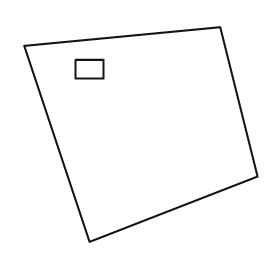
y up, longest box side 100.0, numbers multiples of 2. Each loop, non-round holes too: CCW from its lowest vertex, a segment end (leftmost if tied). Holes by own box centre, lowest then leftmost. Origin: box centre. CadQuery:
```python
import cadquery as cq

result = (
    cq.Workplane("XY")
    .moveTo(-22.0, -46.0)
    .lineTo(50.0, -18.0)
    .lineTo(34.0, 46.0)
    .lineTo(-50.0, 38.0)
    .close()
    .moveTo(-28.0, 24.0)
    .lineTo(-16.0, 24.0)
    .lineTo(-16.0, 32.0)
    .lineTo(-28.0, 32.0)
    .close()
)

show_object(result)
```